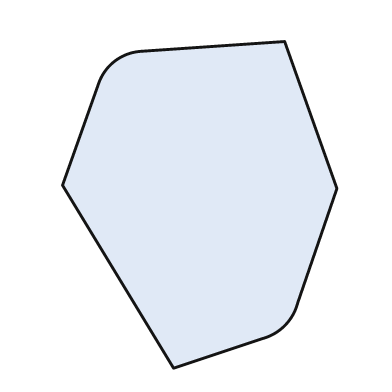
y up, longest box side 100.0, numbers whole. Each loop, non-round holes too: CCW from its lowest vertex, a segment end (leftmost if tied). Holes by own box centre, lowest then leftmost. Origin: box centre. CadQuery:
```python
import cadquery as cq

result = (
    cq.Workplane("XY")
    .moveTo(-8.0, -50.0)
    .lineTo(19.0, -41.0)
    .threePointArc((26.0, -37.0), (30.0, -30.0))
    .lineTo(42.0, 5.0)
    .lineTo(26.0, 50.0)
    .lineTo(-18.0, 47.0)
    .threePointArc((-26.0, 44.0), (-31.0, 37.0))
    .lineTo(-42.0, 6.0)
    .close()
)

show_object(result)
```